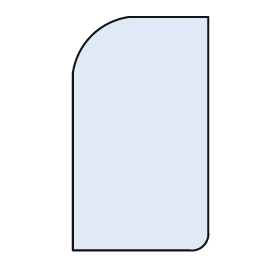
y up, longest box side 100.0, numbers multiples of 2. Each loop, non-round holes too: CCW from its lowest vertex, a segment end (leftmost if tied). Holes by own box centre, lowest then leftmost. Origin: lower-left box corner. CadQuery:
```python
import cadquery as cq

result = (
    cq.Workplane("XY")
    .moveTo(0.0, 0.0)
    .lineTo(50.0, 0.0)
    .threePointArc((56.0, 2.0), (58.0, 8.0))
    .lineTo(58.0, 100.0)
    .lineTo(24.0, 100.0)
    .threePointArc((8.0, 92.0), (0.0, 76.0))
    .close()
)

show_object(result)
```